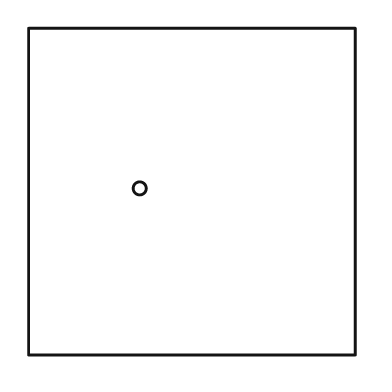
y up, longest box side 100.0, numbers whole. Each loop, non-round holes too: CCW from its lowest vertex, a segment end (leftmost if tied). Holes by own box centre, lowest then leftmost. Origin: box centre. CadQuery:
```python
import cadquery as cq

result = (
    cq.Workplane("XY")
    .moveTo(-50.0, -50.0)
    .lineTo(50.0, -50.0)
    .lineTo(50.0, 50.0)
    .lineTo(-50.0, 50.0)
    .close()
    .moveTo(-16.0, 1.0)
    .circle(2.0)
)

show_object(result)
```